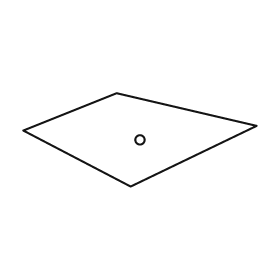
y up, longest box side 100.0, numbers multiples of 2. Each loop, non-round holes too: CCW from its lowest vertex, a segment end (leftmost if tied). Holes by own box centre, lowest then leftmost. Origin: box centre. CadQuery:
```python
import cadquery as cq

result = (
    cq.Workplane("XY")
    .moveTo(-4.0, -20.0)
    .lineTo(50.0, 6.0)
    .lineTo(-10.0, 20.0)
    .lineTo(-50.0, 4.0)
    .close()
    .moveTo(0.0, 0.0)
    .circle(2.0)
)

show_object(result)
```